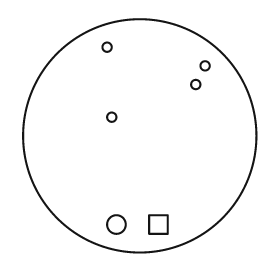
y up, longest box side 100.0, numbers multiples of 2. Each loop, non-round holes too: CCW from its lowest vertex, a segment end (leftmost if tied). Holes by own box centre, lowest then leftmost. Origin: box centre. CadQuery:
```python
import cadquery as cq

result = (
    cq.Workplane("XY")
    .moveTo(0.0, 0.0)
    .circle(50.0)
    .moveTo(-10.0, -38.0)
    .circle(4.0)
    .moveTo(4.0, -42.0)
    .lineTo(12.0, -42.0)
    .lineTo(12.0, -34.0)
    .lineTo(4.0, -34.0)
    .close()
    .moveTo(-12.0, 8.0)
    .circle(2.0)
    .moveTo(24.0, 22.0)
    .circle(2.0)
    .moveTo(28.0, 30.0)
    .circle(2.0)
    .moveTo(-14.0, 38.0)
    .circle(2.0)
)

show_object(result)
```